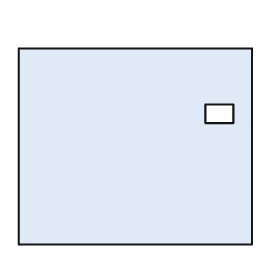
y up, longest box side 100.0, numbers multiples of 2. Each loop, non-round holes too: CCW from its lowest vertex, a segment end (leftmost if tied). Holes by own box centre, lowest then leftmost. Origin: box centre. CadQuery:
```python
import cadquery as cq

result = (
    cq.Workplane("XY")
    .moveTo(-50.0, -42.0)
    .lineTo(50.0, -42.0)
    .lineTo(50.0, 42.0)
    .lineTo(-50.0, 42.0)
    .close()
    .moveTo(30.0, 10.0)
    .lineTo(42.0, 10.0)
    .lineTo(42.0, 18.0)
    .lineTo(30.0, 18.0)
    .close()
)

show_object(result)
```